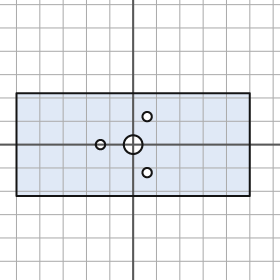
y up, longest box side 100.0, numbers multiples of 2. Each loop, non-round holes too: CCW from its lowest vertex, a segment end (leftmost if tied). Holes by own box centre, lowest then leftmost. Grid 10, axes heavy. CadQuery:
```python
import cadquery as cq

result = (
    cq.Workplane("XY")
    .moveTo(-50.0, -22.0)
    .lineTo(50.0, -22.0)
    .lineTo(50.0, 22.0)
    .lineTo(-50.0, 22.0)
    .close()
    .moveTo(6.0, -12.0)
    .circle(2.0)
    .moveTo(-14.0, 0.0)
    .circle(2.0)
    .moveTo(0.0, 0.0)
    .circle(4.0)
    .moveTo(6.0, 12.0)
    .circle(2.0)
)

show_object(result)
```